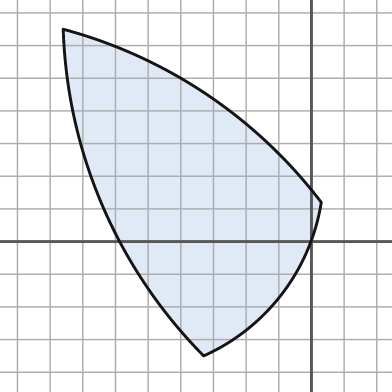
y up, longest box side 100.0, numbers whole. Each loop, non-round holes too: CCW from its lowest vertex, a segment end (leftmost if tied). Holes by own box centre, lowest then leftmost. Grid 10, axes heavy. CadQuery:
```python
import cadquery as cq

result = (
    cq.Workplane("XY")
    .moveTo(-33.0, -35.0)
    .threePointArc((-9.0, -16.0), (3.0, 12.0))
    .threePointArc((-32.0, 45.0), (-76.0, 65.0))
    .threePointArc((-64.0, 11.0), (-33.0, -35.0))
    .close()
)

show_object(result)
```